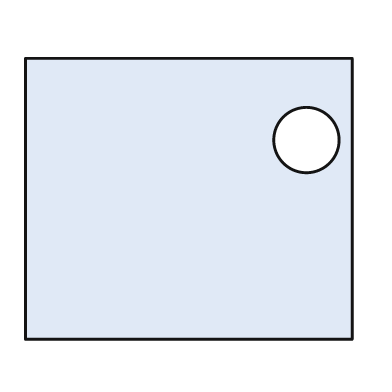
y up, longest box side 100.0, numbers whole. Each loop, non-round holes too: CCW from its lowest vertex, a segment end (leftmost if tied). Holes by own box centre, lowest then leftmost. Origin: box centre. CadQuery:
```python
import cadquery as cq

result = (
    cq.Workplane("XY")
    .moveTo(-50.0, -43.0)
    .lineTo(50.0, -43.0)
    .lineTo(50.0, 43.0)
    .lineTo(-50.0, 43.0)
    .close()
    .moveTo(36.0, 18.0)
    .circle(10.0)
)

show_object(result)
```